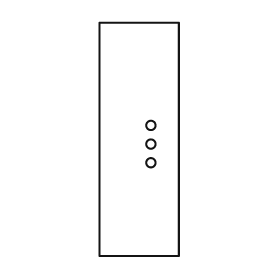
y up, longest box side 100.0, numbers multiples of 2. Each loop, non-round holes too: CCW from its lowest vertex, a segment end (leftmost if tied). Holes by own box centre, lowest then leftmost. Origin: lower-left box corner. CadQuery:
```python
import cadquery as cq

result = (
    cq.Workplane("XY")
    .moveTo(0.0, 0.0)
    .lineTo(34.0, 0.0)
    .lineTo(34.0, 100.0)
    .lineTo(0.0, 100.0)
    .close()
    .moveTo(22.0, 40.0)
    .circle(2.0)
    .moveTo(22.0, 48.0)
    .circle(2.0)
    .moveTo(22.0, 56.0)
    .circle(2.0)
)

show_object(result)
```